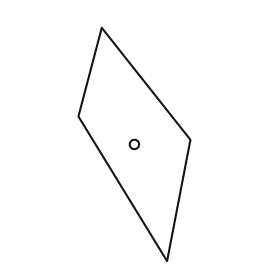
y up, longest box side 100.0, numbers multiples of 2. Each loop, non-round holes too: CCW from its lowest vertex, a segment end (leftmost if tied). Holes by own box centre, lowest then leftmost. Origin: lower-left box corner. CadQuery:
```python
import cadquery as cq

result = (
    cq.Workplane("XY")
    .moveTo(38.0, 0.0)
    .lineTo(48.0, 52.0)
    .lineTo(10.0, 100.0)
    .lineTo(0.0, 62.0)
    .close()
    .moveTo(24.0, 50.0)
    .circle(2.0)
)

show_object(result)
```